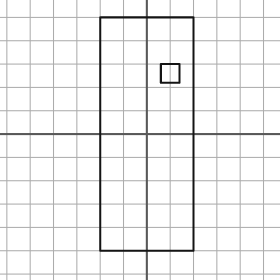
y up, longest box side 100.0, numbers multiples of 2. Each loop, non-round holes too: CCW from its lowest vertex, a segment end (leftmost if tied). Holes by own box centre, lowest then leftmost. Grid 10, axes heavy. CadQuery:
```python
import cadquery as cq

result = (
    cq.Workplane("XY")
    .moveTo(-20.0, -50.0)
    .lineTo(20.0, -50.0)
    .lineTo(20.0, 50.0)
    .lineTo(-20.0, 50.0)
    .close()
    .moveTo(6.0, 22.0)
    .lineTo(14.0, 22.0)
    .lineTo(14.0, 30.0)
    .lineTo(6.0, 30.0)
    .close()
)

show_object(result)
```